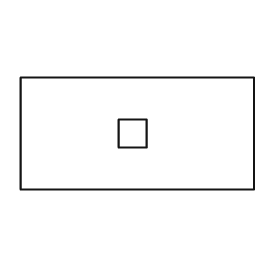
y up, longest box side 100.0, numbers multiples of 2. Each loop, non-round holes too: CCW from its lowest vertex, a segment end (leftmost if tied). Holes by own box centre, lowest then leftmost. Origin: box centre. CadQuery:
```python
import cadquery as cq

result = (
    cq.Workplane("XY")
    .moveTo(-50.0, -24.0)
    .lineTo(50.0, -24.0)
    .lineTo(50.0, 24.0)
    .lineTo(-50.0, 24.0)
    .close()
    .moveTo(-8.0, -6.0)
    .lineTo(4.0, -6.0)
    .lineTo(4.0, 6.0)
    .lineTo(-8.0, 6.0)
    .close()
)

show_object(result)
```